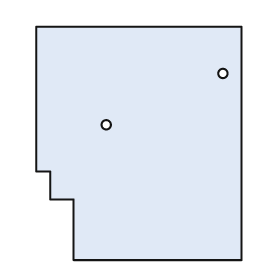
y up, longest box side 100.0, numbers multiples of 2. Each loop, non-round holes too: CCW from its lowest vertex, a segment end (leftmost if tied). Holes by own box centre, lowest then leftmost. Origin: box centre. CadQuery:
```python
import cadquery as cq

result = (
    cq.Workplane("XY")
    .moveTo(-28.0, -50.0)
    .lineTo(44.0, -50.0)
    .lineTo(44.0, 50.0)
    .lineTo(-44.0, 50.0)
    .lineTo(-44.0, -12.0)
    .lineTo(-38.0, -12.0)
    .lineTo(-38.0, -24.0)
    .lineTo(-28.0, -24.0)
    .close()
    .moveTo(-14.0, 8.0)
    .circle(2.0)
    .moveTo(36.0, 30.0)
    .circle(2.0)
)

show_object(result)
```